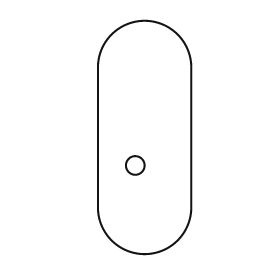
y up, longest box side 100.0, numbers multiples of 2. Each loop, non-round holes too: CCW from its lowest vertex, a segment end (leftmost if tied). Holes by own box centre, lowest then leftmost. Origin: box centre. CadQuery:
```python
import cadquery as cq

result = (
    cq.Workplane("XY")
    .moveTo(-20.0, -30.0)
    .threePointArc((0.0, -50.0), (20.0, -30.0))
    .lineTo(20.0, 30.0)
    .threePointArc((0.0, 50.0), (-20.0, 30.0))
    .close()
    .moveTo(-4.0, -12.0)
    .circle(4.0)
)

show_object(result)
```